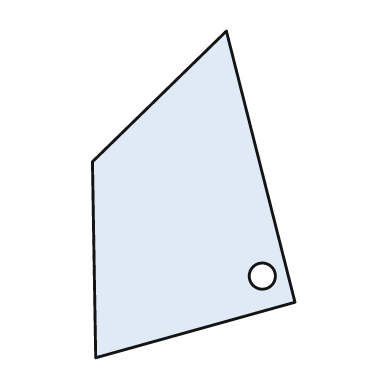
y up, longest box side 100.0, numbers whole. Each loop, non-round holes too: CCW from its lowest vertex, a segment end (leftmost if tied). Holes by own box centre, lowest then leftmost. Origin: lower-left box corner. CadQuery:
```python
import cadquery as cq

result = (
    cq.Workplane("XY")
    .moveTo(1.0, 0.0)
    .lineTo(62.0, 17.0)
    .lineTo(41.0, 100.0)
    .lineTo(0.0, 60.0)
    .close()
    .moveTo(52.0, 25.0)
    .circle(4.0)
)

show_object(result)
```